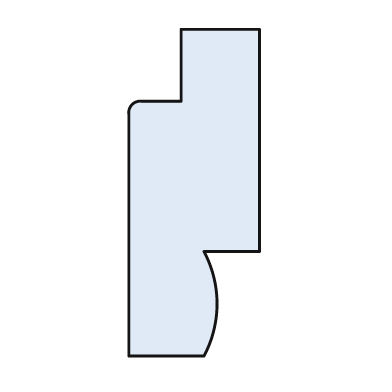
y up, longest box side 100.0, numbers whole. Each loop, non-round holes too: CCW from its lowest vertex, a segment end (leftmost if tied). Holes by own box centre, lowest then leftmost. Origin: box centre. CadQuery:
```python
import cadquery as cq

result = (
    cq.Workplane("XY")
    .moveTo(-20.0, -50.0)
    .lineTo(3.0, -50.0)
    .threePointArc((7.0, -34.0), (3.0, -18.0))
    .lineTo(20.0, -18.0)
    .lineTo(20.0, 50.0)
    .lineTo(-4.0, 50.0)
    .lineTo(-4.0, 28.0)
    .lineTo(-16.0, 28.0)
    .threePointArc((-19.0, 27.0), (-20.0, 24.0))
    .close()
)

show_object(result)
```